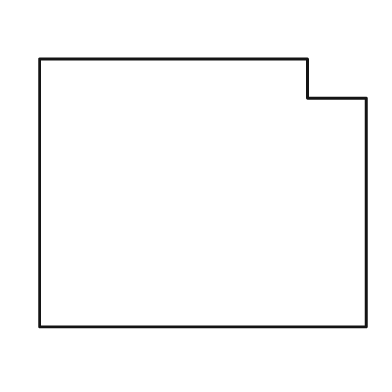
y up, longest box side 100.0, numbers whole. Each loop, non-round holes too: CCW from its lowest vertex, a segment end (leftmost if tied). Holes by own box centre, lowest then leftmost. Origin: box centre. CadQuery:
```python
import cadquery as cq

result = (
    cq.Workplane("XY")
    .moveTo(-50.0, -41.0)
    .lineTo(50.0, -41.0)
    .lineTo(50.0, 29.0)
    .lineTo(32.0, 29.0)
    .lineTo(32.0, 41.0)
    .lineTo(-50.0, 41.0)
    .close()
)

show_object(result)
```